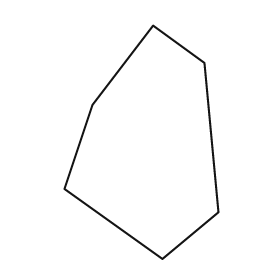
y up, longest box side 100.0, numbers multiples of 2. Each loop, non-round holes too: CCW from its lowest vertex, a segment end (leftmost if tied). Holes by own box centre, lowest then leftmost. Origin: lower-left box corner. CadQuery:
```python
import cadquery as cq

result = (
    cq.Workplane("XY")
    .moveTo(42.0, 0.0)
    .lineTo(66.0, 20.0)
    .lineTo(60.0, 84.0)
    .lineTo(38.0, 100.0)
    .lineTo(12.0, 66.0)
    .lineTo(0.0, 30.0)
    .close()
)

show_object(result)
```